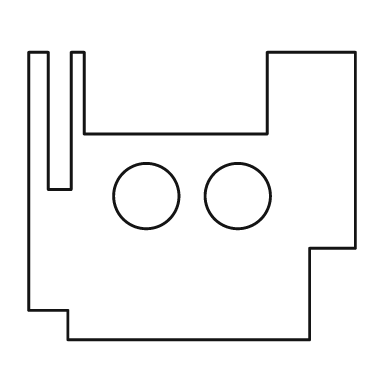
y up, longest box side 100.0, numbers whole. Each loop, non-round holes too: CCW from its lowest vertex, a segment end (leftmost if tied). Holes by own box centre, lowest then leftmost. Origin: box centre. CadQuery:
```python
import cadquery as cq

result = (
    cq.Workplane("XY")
    .moveTo(-38.0, -44.0)
    .lineTo(36.0, -44.0)
    .lineTo(36.0, -16.0)
    .lineTo(50.0, -16.0)
    .lineTo(50.0, 44.0)
    .lineTo(23.0, 44.0)
    .lineTo(23.0, 19.0)
    .lineTo(-33.0, 19.0)
    .lineTo(-33.0, 44.0)
    .lineTo(-37.0, 44.0)
    .lineTo(-37.0, 2.0)
    .lineTo(-44.0, 2.0)
    .lineTo(-44.0, 44.0)
    .lineTo(-50.0, 44.0)
    .lineTo(-50.0, -35.0)
    .lineTo(-38.0, -35.0)
    .close()
    .moveTo(-14.0, 0.0)
    .circle(10.0)
    .moveTo(14.0, 0.0)
    .circle(10.0)
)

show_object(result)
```